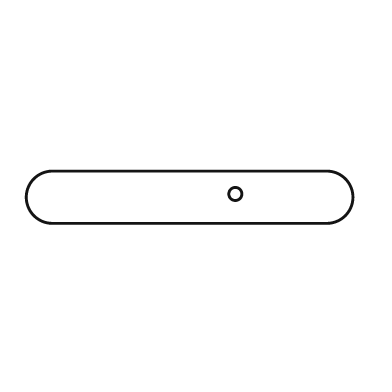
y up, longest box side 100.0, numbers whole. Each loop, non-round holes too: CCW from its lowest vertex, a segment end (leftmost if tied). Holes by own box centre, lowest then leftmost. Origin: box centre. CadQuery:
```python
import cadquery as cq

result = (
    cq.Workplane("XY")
    .moveTo(-42.0, -8.0)
    .lineTo(42.0, -8.0)
    .threePointArc((50.0, 0.0), (42.0, 8.0))
    .lineTo(-42.0, 8.0)
    .threePointArc((-50.0, 0.0), (-42.0, -8.0))
    .close()
    .moveTo(14.0, 1.0)
    .circle(2.0)
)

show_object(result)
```